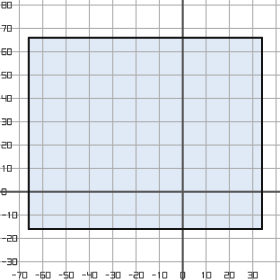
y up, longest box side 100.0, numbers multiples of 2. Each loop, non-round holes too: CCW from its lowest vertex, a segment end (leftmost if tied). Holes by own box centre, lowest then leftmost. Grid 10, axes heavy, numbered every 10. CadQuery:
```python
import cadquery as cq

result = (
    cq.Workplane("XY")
    .moveTo(-66.0, -16.0)
    .lineTo(34.0, -16.0)
    .lineTo(34.0, 66.0)
    .lineTo(-66.0, 66.0)
    .close()
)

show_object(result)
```